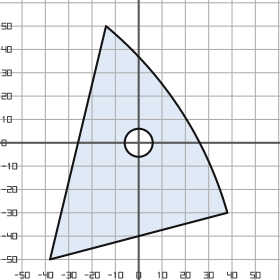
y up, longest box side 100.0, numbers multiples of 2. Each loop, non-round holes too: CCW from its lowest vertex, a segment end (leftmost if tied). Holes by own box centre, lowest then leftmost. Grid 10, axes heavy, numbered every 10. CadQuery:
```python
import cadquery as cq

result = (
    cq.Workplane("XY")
    .moveTo(-38.0, -50.0)
    .lineTo(38.0, -30.0)
    .threePointArc((18.0, 14.0), (-14.0, 50.0))
    .close()
    .moveTo(0.0, 0.0)
    .circle(6.0)
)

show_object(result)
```